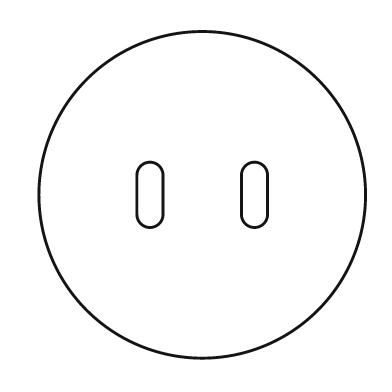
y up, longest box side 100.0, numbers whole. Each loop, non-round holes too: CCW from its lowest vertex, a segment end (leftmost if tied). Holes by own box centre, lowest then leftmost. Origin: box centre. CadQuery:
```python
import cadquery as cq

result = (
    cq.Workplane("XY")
    .moveTo(0.0, 0.0)
    .circle(50.0)
    .moveTo(-20.0, -6.0)
    .threePointArc((-16.0, -10.0), (-12.0, -6.0))
    .lineTo(-12.0, 6.0)
    .threePointArc((-16.0, 10.0), (-20.0, 6.0))
    .close()
    .moveTo(12.0, -6.0)
    .threePointArc((16.0, -10.0), (20.0, -6.0))
    .lineTo(20.0, 6.0)
    .threePointArc((16.0, 10.0), (12.0, 6.0))
    .close()
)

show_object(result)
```